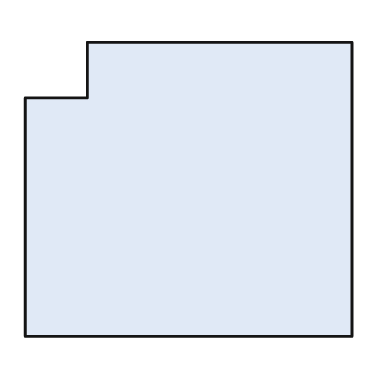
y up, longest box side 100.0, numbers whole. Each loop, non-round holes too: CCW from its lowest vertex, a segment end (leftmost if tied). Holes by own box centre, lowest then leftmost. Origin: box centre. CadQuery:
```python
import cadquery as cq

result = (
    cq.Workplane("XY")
    .moveTo(-50.0, -45.0)
    .lineTo(50.0, -45.0)
    .lineTo(50.0, 45.0)
    .lineTo(-31.0, 45.0)
    .lineTo(-31.0, 28.0)
    .lineTo(-50.0, 28.0)
    .close()
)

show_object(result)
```